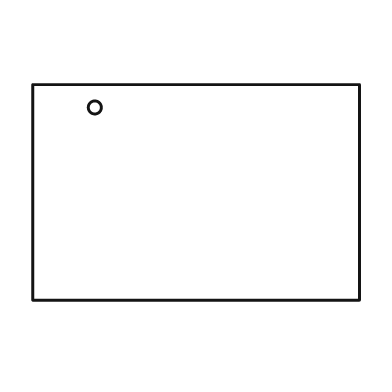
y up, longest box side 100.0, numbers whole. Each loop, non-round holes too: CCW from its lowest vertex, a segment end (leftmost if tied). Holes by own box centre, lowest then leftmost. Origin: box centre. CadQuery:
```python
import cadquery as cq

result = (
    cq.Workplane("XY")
    .moveTo(-50.0, -33.0)
    .lineTo(50.0, -33.0)
    .lineTo(50.0, 33.0)
    .lineTo(-50.0, 33.0)
    .close()
    .moveTo(-31.0, 26.0)
    .circle(2.0)
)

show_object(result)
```